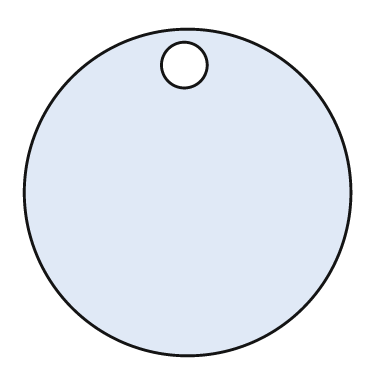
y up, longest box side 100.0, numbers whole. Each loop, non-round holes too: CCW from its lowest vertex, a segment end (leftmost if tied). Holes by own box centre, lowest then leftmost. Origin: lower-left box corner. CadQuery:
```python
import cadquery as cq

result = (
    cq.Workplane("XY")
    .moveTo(50.0, 50.0)
    .circle(50.0)
    .moveTo(49.0, 89.0)
    .circle(7.0)
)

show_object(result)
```